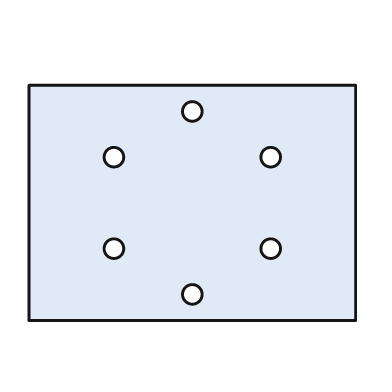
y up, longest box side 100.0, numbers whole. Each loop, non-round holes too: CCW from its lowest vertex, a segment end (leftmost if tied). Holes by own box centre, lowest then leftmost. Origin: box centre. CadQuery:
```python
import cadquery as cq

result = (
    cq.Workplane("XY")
    .moveTo(-50.0, -36.0)
    .lineTo(50.0, -36.0)
    .lineTo(50.0, 36.0)
    .lineTo(-50.0, 36.0)
    .close()
    .moveTo(0.0, -28.0)
    .circle(3.0)
    .moveTo(-24.0, -14.0)
    .circle(3.0)
    .moveTo(24.0, -14.0)
    .circle(3.0)
    .moveTo(-24.0, 14.0)
    .circle(3.0)
    .moveTo(24.0, 14.0)
    .circle(3.0)
    .moveTo(0.0, 28.0)
    .circle(3.0)
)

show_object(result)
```